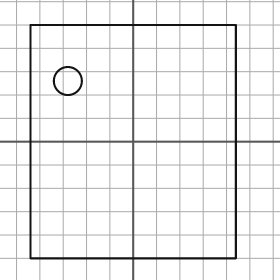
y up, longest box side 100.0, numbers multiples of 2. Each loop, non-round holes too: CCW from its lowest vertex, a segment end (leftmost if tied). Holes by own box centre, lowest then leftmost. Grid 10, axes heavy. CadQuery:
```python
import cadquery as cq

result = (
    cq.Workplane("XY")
    .moveTo(-44.0, -50.0)
    .lineTo(44.0, -50.0)
    .lineTo(44.0, 50.0)
    .lineTo(-44.0, 50.0)
    .close()
    .moveTo(-28.0, 26.0)
    .circle(6.0)
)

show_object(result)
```